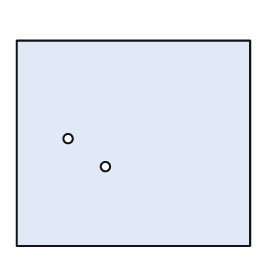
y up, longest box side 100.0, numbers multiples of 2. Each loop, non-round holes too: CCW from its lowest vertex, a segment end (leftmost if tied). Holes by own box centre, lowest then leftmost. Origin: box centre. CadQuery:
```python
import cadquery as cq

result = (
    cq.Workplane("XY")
    .moveTo(-50.0, -44.0)
    .lineTo(50.0, -44.0)
    .lineTo(50.0, 44.0)
    .lineTo(-50.0, 44.0)
    .close()
    .moveTo(-12.0, -10.0)
    .circle(2.0)
    .moveTo(-28.0, 2.0)
    .circle(2.0)
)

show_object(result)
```